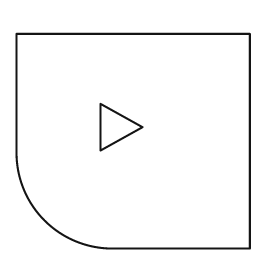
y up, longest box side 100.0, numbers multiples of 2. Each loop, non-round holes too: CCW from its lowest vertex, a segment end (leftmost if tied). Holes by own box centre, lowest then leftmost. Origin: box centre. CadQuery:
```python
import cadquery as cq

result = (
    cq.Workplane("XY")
    .moveTo(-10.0, -46.0)
    .lineTo(50.0, -46.0)
    .lineTo(50.0, 46.0)
    .lineTo(-50.0, 46.0)
    .lineTo(-50.0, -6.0)
    .threePointArc((-38.0, -34.0), (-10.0, -46.0))
    .close()
    .moveTo(-14.0, -4.0)
    .lineTo(4.0, 6.0)
    .lineTo(-14.0, 16.0)
    .close()
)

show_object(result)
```